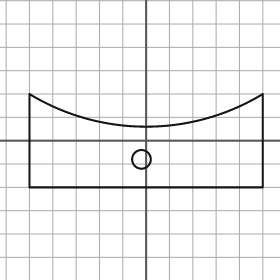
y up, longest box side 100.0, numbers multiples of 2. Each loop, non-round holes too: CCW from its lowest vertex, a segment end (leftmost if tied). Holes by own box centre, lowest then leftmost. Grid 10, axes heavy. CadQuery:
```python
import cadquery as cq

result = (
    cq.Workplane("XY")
    .moveTo(-50.0, -20.0)
    .lineTo(50.0, -20.0)
    .lineTo(50.0, 20.0)
    .threePointArc((0.0, 6.0), (-50.0, 20.0))
    .close()
    .moveTo(-2.0, -8.0)
    .circle(4.0)
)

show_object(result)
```